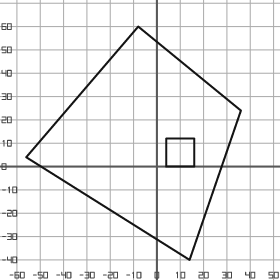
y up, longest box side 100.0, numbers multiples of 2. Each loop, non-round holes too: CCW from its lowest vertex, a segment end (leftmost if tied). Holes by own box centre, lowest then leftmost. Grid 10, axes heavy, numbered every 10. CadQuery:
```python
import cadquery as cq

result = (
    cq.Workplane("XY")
    .moveTo(14.0, -40.0)
    .lineTo(36.0, 24.0)
    .lineTo(-8.0, 60.0)
    .lineTo(-56.0, 4.0)
    .close()
    .moveTo(4.0, 0.0)
    .lineTo(16.0, 0.0)
    .lineTo(16.0, 12.0)
    .lineTo(4.0, 12.0)
    .close()
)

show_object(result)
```